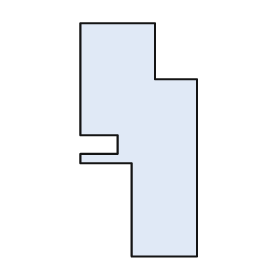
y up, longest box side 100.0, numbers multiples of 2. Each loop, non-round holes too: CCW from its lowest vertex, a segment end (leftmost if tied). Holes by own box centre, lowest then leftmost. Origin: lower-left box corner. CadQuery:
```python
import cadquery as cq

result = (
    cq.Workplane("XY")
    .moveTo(22.0, 0.0)
    .lineTo(50.0, 0.0)
    .lineTo(50.0, 76.0)
    .lineTo(32.0, 76.0)
    .lineTo(32.0, 100.0)
    .lineTo(0.0, 100.0)
    .lineTo(0.0, 52.0)
    .lineTo(16.0, 52.0)
    .lineTo(16.0, 44.0)
    .lineTo(0.0, 44.0)
    .lineTo(0.0, 40.0)
    .lineTo(22.0, 40.0)
    .close()
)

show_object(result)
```